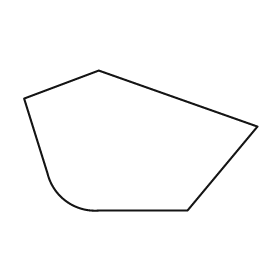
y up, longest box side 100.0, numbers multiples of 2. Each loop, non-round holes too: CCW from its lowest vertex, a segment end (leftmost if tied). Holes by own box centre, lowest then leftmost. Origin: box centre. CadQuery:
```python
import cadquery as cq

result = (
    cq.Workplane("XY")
    .moveTo(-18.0, -30.0)
    .lineTo(20.0, -30.0)
    .lineTo(50.0, 6.0)
    .lineTo(-18.0, 30.0)
    .lineTo(-50.0, 18.0)
    .lineTo(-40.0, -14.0)
    .threePointArc((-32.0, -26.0), (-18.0, -30.0))
    .close()
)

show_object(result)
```